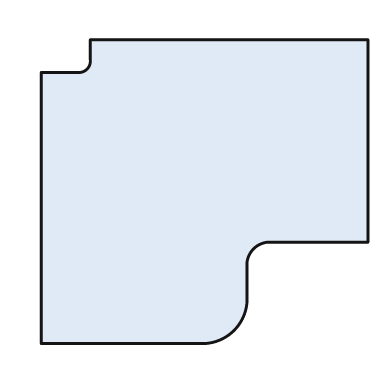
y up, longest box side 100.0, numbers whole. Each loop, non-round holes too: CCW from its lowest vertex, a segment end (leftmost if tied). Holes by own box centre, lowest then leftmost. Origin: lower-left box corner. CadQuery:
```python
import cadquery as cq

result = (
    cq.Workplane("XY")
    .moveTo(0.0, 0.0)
    .lineTo(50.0, 0.0)
    .threePointArc((59.0, 4.0), (63.0, 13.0))
    .lineTo(63.0, 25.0)
    .threePointArc((65.0, 29.0), (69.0, 31.0))
    .lineTo(100.0, 31.0)
    .lineTo(100.0, 93.0)
    .lineTo(15.0, 93.0)
    .lineTo(15.0, 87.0)
    .threePointArc((14.0, 84.0), (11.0, 83.0))
    .lineTo(0.0, 83.0)
    .close()
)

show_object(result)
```